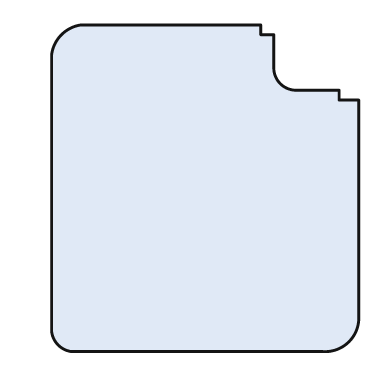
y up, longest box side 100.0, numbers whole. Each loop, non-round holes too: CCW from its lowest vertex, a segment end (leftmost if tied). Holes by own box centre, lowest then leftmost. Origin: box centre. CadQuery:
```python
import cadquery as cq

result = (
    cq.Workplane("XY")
    .moveTo(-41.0, -50.0)
    .lineTo(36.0, -50.0)
    .threePointArc((44.0, -47.0), (47.0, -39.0))
    .lineTo(47.0, 27.0)
    .lineTo(41.0, 27.0)
    .lineTo(41.0, 30.0)
    .lineTo(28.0, 30.0)
    .threePointArc((23.0, 32.0), (21.0, 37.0))
    .lineTo(21.0, 47.0)
    .lineTo(17.0, 47.0)
    .lineTo(17.0, 50.0)
    .lineTo(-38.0, 50.0)
    .threePointArc((-44.0, 47.0), (-47.0, 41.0))
    .lineTo(-47.0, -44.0)
    .threePointArc((-45.0, -48.0), (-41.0, -50.0))
    .close()
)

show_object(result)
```